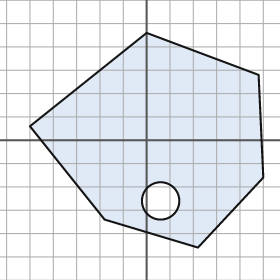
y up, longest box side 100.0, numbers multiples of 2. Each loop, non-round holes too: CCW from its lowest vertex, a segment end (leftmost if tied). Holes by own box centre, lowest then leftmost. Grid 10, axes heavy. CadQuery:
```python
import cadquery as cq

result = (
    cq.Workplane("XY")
    .moveTo(22.0, -46.0)
    .lineTo(50.0, -16.0)
    .lineTo(48.0, 28.0)
    .lineTo(0.0, 46.0)
    .lineTo(-50.0, 6.0)
    .lineTo(-18.0, -34.0)
    .close()
    .moveTo(6.0, -26.0)
    .circle(8.0)
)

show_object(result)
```